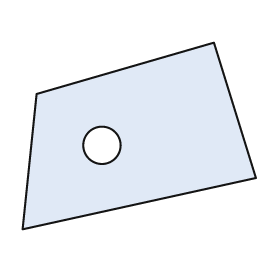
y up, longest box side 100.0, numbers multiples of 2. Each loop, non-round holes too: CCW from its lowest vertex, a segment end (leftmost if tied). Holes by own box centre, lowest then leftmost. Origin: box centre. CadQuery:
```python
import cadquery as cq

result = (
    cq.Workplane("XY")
    .moveTo(-50.0, -40.0)
    .lineTo(50.0, -18.0)
    .lineTo(32.0, 40.0)
    .lineTo(-44.0, 18.0)
    .close()
    .moveTo(-16.0, -4.0)
    .circle(8.0)
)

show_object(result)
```